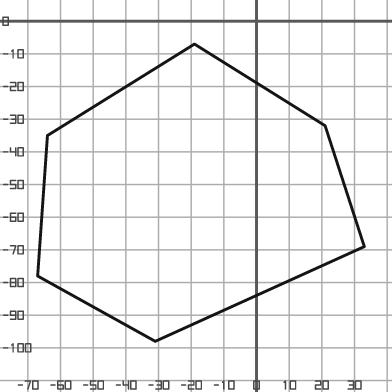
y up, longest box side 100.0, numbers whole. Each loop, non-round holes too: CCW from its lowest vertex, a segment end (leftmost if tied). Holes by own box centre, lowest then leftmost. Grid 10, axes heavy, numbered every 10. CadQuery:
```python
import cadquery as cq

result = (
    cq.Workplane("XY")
    .moveTo(-31.0, -98.0)
    .lineTo(33.0, -69.0)
    .lineTo(21.0, -32.0)
    .lineTo(-19.0, -7.0)
    .lineTo(-64.0, -35.0)
    .lineTo(-67.0, -78.0)
    .close()
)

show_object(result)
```